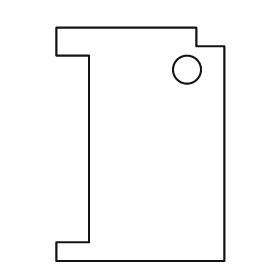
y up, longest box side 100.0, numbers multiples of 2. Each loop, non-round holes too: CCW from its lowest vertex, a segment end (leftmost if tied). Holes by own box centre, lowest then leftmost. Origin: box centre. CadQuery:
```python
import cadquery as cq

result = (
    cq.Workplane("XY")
    .moveTo(-36.0, -50.0)
    .lineTo(36.0, -50.0)
    .lineTo(36.0, 42.0)
    .lineTo(24.0, 42.0)
    .lineTo(24.0, 50.0)
    .lineTo(-36.0, 50.0)
    .lineTo(-36.0, 38.0)
    .lineTo(-22.0, 38.0)
    .lineTo(-22.0, -42.0)
    .lineTo(-36.0, -42.0)
    .close()
    .moveTo(20.0, 32.0)
    .circle(6.0)
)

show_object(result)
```